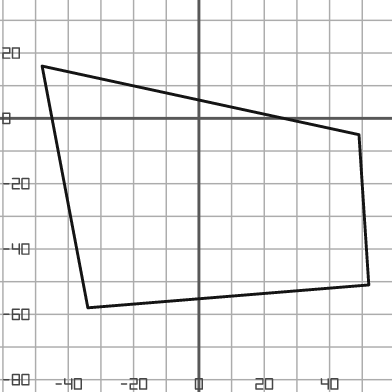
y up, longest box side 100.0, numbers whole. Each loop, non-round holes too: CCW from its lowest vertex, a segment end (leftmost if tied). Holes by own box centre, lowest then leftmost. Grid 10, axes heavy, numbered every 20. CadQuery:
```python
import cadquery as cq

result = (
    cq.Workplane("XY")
    .moveTo(-34.0, -58.0)
    .lineTo(52.0, -51.0)
    .lineTo(49.0, -5.0)
    .lineTo(-48.0, 16.0)
    .close()
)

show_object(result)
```